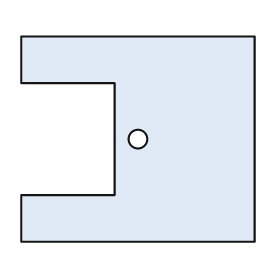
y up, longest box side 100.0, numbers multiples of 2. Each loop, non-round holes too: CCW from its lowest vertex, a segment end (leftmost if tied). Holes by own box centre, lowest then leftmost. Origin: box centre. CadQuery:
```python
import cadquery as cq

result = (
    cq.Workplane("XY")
    .moveTo(-50.0, -44.0)
    .lineTo(50.0, -44.0)
    .lineTo(50.0, 44.0)
    .lineTo(-50.0, 44.0)
    .lineTo(-50.0, 24.0)
    .lineTo(-10.0, 24.0)
    .lineTo(-10.0, -24.0)
    .lineTo(-50.0, -24.0)
    .close()
    .moveTo(0.0, 0.0)
    .circle(4.0)
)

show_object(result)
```